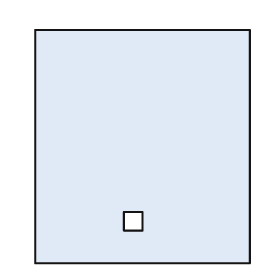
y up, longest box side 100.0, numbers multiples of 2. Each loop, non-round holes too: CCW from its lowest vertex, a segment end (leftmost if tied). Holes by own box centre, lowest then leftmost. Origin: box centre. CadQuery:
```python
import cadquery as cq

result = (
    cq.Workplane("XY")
    .moveTo(-46.0, -50.0)
    .lineTo(46.0, -50.0)
    .lineTo(46.0, 50.0)
    .lineTo(-46.0, 50.0)
    .close()
    .moveTo(-8.0, -36.0)
    .lineTo(0.0, -36.0)
    .lineTo(0.0, -28.0)
    .lineTo(-8.0, -28.0)
    .close()
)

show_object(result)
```